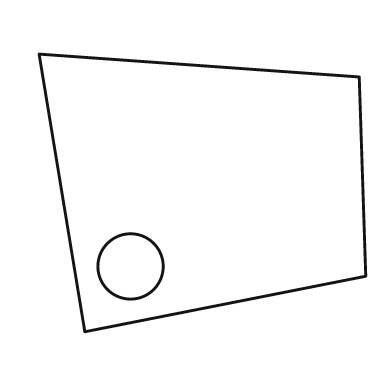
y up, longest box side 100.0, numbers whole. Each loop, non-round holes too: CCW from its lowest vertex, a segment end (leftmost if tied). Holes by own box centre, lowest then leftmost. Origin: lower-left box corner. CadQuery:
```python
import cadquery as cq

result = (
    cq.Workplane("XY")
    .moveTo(14.0, 0.0)
    .lineTo(100.0, 17.0)
    .lineTo(98.0, 78.0)
    .lineTo(0.0, 85.0)
    .close()
    .moveTo(28.0, 20.0)
    .circle(10.0)
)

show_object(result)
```